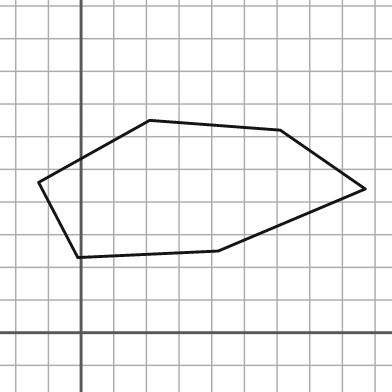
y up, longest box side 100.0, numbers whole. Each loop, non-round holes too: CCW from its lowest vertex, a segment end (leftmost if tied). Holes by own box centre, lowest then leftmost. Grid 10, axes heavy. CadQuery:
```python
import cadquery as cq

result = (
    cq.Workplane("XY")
    .moveTo(-1.0, 23.0)
    .lineTo(42.0, 25.0)
    .lineTo(87.0, 44.0)
    .lineTo(61.0, 62.0)
    .lineTo(21.0, 65.0)
    .lineTo(-13.0, 46.0)
    .close()
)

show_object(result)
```